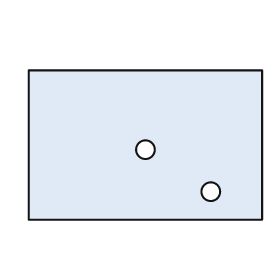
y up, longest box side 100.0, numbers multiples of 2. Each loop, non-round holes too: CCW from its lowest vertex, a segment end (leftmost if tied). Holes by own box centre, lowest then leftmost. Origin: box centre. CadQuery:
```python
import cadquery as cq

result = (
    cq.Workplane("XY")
    .moveTo(-50.0, -32.0)
    .lineTo(50.0, -32.0)
    .lineTo(50.0, 32.0)
    .lineTo(-50.0, 32.0)
    .close()
    .moveTo(28.0, -20.0)
    .circle(4.0)
    .moveTo(0.0, -2.0)
    .circle(4.0)
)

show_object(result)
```